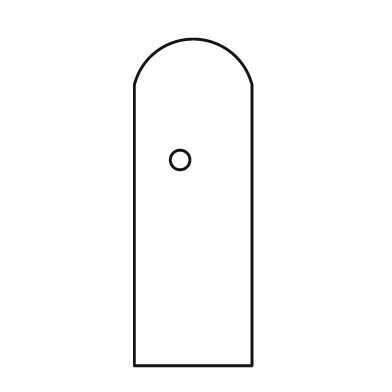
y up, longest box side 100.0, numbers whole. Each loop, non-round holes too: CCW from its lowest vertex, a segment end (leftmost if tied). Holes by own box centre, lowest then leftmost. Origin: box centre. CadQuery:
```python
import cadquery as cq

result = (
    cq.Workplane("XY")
    .moveTo(-18.0, -50.0)
    .lineTo(18.0, -50.0)
    .lineTo(18.0, 36.0)
    .threePointArc((0.0, 50.0), (-18.0, 36.0))
    .close()
    .moveTo(-4.0, 13.0)
    .circle(3.0)
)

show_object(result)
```